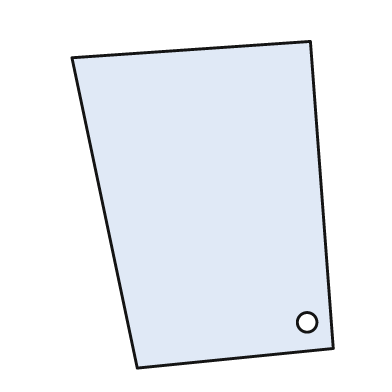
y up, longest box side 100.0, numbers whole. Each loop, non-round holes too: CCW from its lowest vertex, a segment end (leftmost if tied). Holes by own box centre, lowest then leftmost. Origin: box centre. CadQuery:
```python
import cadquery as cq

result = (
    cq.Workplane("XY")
    .moveTo(-20.0, -50.0)
    .lineTo(40.0, -44.0)
    .lineTo(33.0, 50.0)
    .lineTo(-40.0, 45.0)
    .close()
    .moveTo(32.0, -36.0)
    .circle(3.0)
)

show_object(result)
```